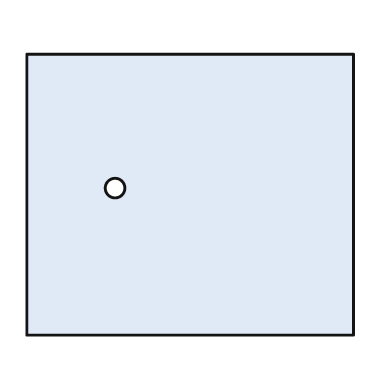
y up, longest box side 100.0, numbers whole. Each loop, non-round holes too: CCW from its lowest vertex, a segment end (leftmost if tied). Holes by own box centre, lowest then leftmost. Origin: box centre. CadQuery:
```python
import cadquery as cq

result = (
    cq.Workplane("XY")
    .moveTo(-50.0, -43.0)
    .lineTo(50.0, -43.0)
    .lineTo(50.0, 43.0)
    .lineTo(-50.0, 43.0)
    .close()
    .moveTo(-23.0, 2.0)
    .circle(3.0)
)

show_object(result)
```